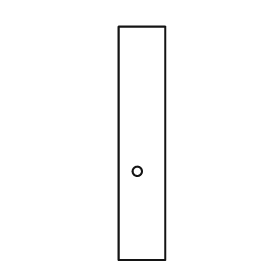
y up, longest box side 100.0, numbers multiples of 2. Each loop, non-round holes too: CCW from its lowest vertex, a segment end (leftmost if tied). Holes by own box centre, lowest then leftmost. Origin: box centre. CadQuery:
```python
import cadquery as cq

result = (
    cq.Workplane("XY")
    .moveTo(-10.0, -50.0)
    .lineTo(10.0, -50.0)
    .lineTo(10.0, 50.0)
    .lineTo(-10.0, 50.0)
    .close()
    .moveTo(-2.0, -12.0)
    .circle(2.0)
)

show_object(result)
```